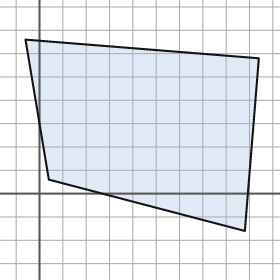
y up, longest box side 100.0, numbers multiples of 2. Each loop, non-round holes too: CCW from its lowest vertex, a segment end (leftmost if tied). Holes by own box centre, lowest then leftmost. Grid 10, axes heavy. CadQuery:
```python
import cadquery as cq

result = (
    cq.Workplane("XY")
    .moveTo(88.0, -16.0)
    .lineTo(94.0, 58.0)
    .lineTo(-6.0, 66.0)
    .lineTo(4.0, 6.0)
    .close()
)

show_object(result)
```